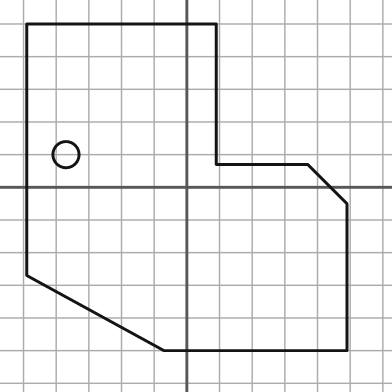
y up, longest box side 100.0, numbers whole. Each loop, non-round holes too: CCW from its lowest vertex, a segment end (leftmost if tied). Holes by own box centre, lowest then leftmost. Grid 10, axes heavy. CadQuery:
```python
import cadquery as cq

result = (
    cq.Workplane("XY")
    .moveTo(-7.0, -50.0)
    .lineTo(49.0, -50.0)
    .lineTo(49.0, -5.0)
    .lineTo(37.0, 7.0)
    .lineTo(9.0, 7.0)
    .lineTo(9.0, 50.0)
    .lineTo(-49.0, 50.0)
    .lineTo(-49.0, -27.0)
    .close()
    .moveTo(-37.0, 10.0)
    .circle(4.0)
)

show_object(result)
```